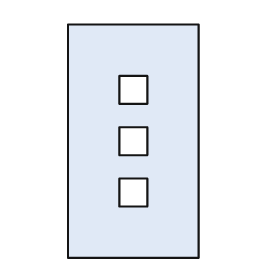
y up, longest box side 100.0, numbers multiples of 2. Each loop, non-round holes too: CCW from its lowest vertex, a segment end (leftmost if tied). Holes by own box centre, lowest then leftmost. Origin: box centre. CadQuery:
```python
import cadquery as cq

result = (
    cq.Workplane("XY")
    .moveTo(-28.0, -50.0)
    .lineTo(28.0, -50.0)
    .lineTo(28.0, 50.0)
    .lineTo(-28.0, 50.0)
    .close()
    .moveTo(-6.0, -28.0)
    .lineTo(6.0, -28.0)
    .lineTo(6.0, -16.0)
    .lineTo(-6.0, -16.0)
    .close()
    .moveTo(-6.0, -6.0)
    .lineTo(6.0, -6.0)
    .lineTo(6.0, 6.0)
    .lineTo(-6.0, 6.0)
    .close()
    .moveTo(-6.0, 16.0)
    .lineTo(6.0, 16.0)
    .lineTo(6.0, 28.0)
    .lineTo(-6.0, 28.0)
    .close()
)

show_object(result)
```